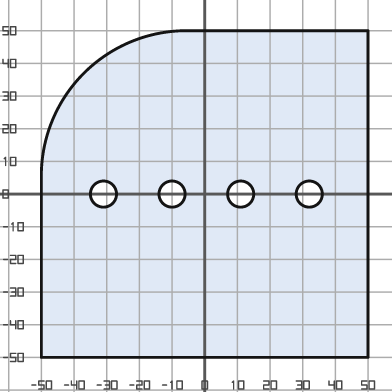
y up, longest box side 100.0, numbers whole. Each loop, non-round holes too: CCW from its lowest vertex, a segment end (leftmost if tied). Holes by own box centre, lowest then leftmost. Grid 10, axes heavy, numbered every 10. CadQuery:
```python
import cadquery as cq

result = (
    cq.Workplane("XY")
    .moveTo(-50.0, -50.0)
    .lineTo(50.0, -50.0)
    .lineTo(50.0, 50.0)
    .lineTo(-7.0, 50.0)
    .threePointArc((-37.0, 37.0), (-50.0, 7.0))
    .close()
    .moveTo(-31.0, 0.0)
    .circle(4.0)
    .moveTo(-10.0, 0.0)
    .circle(4.0)
    .moveTo(11.0, 0.0)
    .circle(4.0)
    .moveTo(32.0, 0.0)
    .circle(4.0)
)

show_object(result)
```